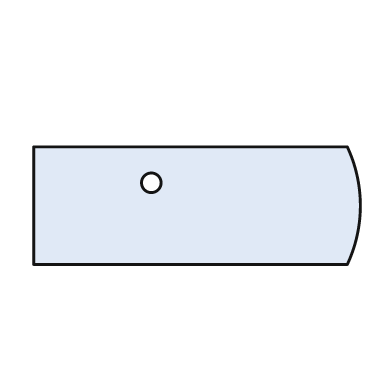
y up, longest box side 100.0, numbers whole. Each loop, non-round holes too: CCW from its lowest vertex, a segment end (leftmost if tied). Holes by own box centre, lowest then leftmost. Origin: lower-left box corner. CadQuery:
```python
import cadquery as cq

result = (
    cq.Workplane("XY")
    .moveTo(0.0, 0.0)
    .lineTo(96.0, 0.0)
    .threePointArc((100.0, 18.0), (96.0, 36.0))
    .lineTo(0.0, 36.0)
    .close()
    .moveTo(36.0, 25.0)
    .circle(3.0)
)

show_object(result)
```